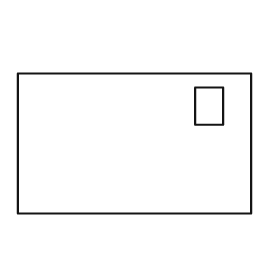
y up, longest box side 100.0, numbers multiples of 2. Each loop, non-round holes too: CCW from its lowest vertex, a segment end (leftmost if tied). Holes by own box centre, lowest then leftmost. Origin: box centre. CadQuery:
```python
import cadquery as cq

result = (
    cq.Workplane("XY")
    .moveTo(-50.0, -30.0)
    .lineTo(50.0, -30.0)
    .lineTo(50.0, 30.0)
    .lineTo(-50.0, 30.0)
    .close()
    .moveTo(26.0, 8.0)
    .lineTo(38.0, 8.0)
    .lineTo(38.0, 24.0)
    .lineTo(26.0, 24.0)
    .close()
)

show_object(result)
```